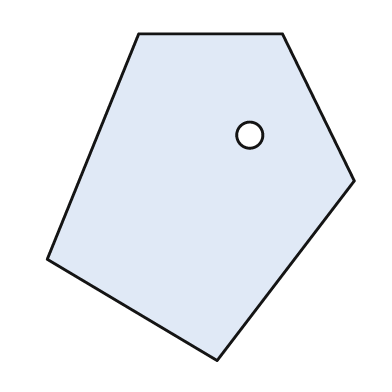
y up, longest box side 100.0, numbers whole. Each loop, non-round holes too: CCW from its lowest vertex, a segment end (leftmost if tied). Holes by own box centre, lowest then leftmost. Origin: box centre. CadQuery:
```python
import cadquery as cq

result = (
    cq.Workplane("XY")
    .moveTo(5.0, -50.0)
    .lineTo(47.0, 5.0)
    .lineTo(25.0, 50.0)
    .lineTo(-19.0, 50.0)
    .lineTo(-47.0, -19.0)
    .close()
    .moveTo(15.0, 19.0)
    .circle(4.0)
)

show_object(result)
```